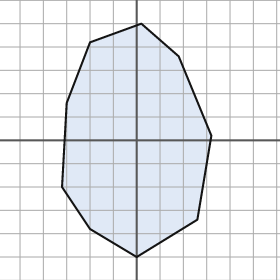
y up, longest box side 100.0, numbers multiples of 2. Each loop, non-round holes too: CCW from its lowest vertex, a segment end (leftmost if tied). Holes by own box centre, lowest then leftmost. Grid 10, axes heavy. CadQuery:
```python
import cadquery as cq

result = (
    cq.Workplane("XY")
    .moveTo(0.0, -50.0)
    .lineTo(26.0, -34.0)
    .lineTo(32.0, 2.0)
    .lineTo(18.0, 36.0)
    .lineTo(2.0, 50.0)
    .lineTo(-20.0, 42.0)
    .lineTo(-30.0, 16.0)
    .lineTo(-32.0, -20.0)
    .lineTo(-20.0, -38.0)
    .close()
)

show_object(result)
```